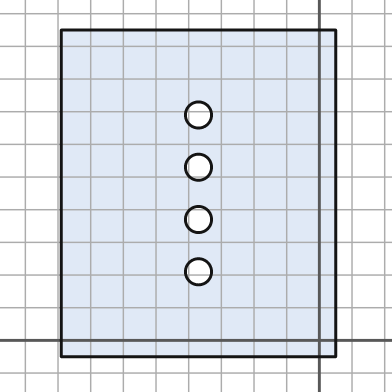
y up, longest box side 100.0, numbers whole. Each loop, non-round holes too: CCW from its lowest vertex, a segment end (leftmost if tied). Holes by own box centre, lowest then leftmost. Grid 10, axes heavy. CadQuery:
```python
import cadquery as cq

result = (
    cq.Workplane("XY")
    .moveTo(-79.0, -5.0)
    .lineTo(5.0, -5.0)
    .lineTo(5.0, 95.0)
    .lineTo(-79.0, 95.0)
    .close()
    .moveTo(-37.0, 21.0)
    .circle(4.0)
    .moveTo(-37.0, 37.0)
    .circle(4.0)
    .moveTo(-37.0, 53.0)
    .circle(4.0)
    .moveTo(-37.0, 69.0)
    .circle(4.0)
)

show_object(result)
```